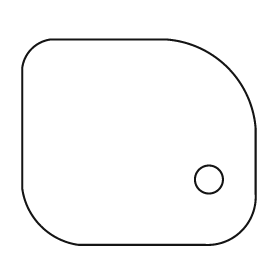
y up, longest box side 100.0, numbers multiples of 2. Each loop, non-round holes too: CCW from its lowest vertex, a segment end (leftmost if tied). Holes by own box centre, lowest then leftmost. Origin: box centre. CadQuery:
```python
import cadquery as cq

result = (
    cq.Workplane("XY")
    .moveTo(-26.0, -44.0)
    .lineTo(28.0, -44.0)
    .threePointArc((44.0, -38.0), (50.0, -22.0))
    .lineTo(50.0, 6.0)
    .threePointArc((38.0, 32.0), (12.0, 44.0))
    .lineTo(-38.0, 44.0)
    .threePointArc((-46.0, 40.0), (-50.0, 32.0))
    .lineTo(-50.0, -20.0)
    .threePointArc((-42.0, -36.0), (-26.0, -44.0))
    .close()
    .moveTo(30.0, -16.0)
    .circle(6.0)
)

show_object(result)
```